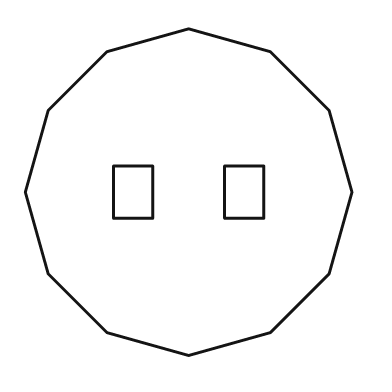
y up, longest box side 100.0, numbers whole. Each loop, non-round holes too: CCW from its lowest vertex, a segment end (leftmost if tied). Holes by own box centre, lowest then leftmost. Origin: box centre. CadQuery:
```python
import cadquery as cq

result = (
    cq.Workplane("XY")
    .moveTo(0.0, -50.0)
    .lineTo(25.0, -43.0)
    .lineTo(43.0, -25.0)
    .lineTo(50.0, 0.0)
    .lineTo(43.0, 25.0)
    .lineTo(25.0, 43.0)
    .lineTo(0.0, 50.0)
    .lineTo(-25.0, 43.0)
    .lineTo(-43.0, 25.0)
    .lineTo(-50.0, 0.0)
    .lineTo(-43.0, -25.0)
    .lineTo(-25.0, -43.0)
    .close()
    .moveTo(-23.0, -8.0)
    .lineTo(-11.0, -8.0)
    .lineTo(-11.0, 8.0)
    .lineTo(-23.0, 8.0)
    .close()
    .moveTo(11.0, -8.0)
    .lineTo(23.0, -8.0)
    .lineTo(23.0, 8.0)
    .lineTo(11.0, 8.0)
    .close()
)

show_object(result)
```